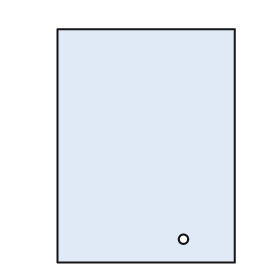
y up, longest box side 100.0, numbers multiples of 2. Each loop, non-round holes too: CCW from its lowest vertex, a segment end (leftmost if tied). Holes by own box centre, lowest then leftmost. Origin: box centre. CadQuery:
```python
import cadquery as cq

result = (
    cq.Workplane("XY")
    .moveTo(-38.0, -50.0)
    .lineTo(38.0, -50.0)
    .lineTo(38.0, 50.0)
    .lineTo(-38.0, 50.0)
    .close()
    .moveTo(16.0, -40.0)
    .circle(2.0)
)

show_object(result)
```